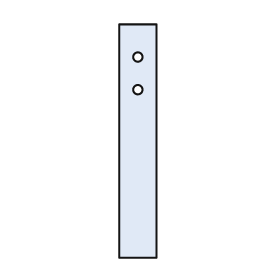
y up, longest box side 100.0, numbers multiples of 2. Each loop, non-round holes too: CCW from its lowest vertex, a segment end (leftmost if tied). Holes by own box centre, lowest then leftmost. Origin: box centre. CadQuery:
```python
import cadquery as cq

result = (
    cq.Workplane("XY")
    .moveTo(-8.0, -50.0)
    .lineTo(8.0, -50.0)
    .lineTo(8.0, 50.0)
    .lineTo(-8.0, 50.0)
    .close()
    .moveTo(0.0, 22.0)
    .circle(2.0)
    .moveTo(0.0, 36.0)
    .circle(2.0)
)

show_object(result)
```